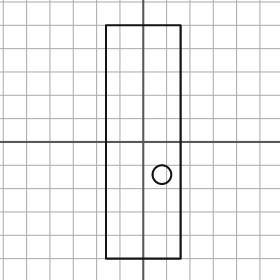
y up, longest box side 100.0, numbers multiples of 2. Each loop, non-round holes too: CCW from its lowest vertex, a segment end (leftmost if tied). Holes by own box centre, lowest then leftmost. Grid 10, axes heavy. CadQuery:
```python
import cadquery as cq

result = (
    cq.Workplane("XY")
    .moveTo(-16.0, -50.0)
    .lineTo(16.0, -50.0)
    .lineTo(16.0, 50.0)
    .lineTo(-16.0, 50.0)
    .close()
    .moveTo(8.0, -14.0)
    .circle(4.0)
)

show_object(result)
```